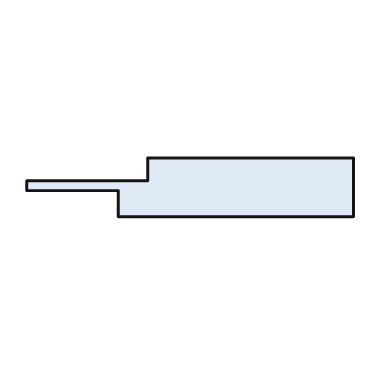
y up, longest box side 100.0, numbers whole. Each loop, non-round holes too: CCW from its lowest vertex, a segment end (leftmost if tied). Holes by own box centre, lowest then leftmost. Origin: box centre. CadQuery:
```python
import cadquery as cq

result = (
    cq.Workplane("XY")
    .moveTo(-22.0, -9.0)
    .lineTo(50.0, -9.0)
    .lineTo(50.0, 9.0)
    .lineTo(-13.0, 9.0)
    .lineTo(-13.0, 2.0)
    .lineTo(-50.0, 2.0)
    .lineTo(-50.0, -1.0)
    .lineTo(-22.0, -1.0)
    .close()
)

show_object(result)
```